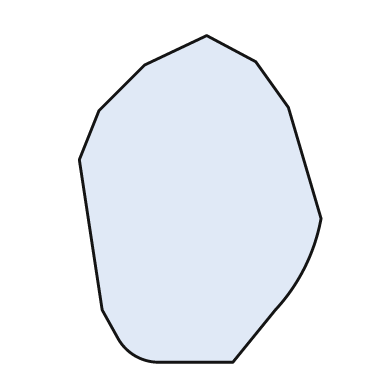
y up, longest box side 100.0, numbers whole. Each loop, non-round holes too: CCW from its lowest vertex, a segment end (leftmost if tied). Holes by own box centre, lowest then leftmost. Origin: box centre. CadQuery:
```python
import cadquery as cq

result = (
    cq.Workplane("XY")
    .moveTo(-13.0, -50.0)
    .lineTo(10.0, -50.0)
    .lineTo(23.0, -34.0)
    .threePointArc((32.0, -21.0), (37.0, -6.0))
    .lineTo(27.0, 28.0)
    .lineTo(17.0, 42.0)
    .lineTo(2.0, 50.0)
    .lineTo(-17.0, 41.0)
    .lineTo(-31.0, 27.0)
    .lineTo(-37.0, 12.0)
    .lineTo(-30.0, -34.0)
    .lineTo(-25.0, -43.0)
    .threePointArc((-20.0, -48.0), (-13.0, -50.0))
    .close()
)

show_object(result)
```